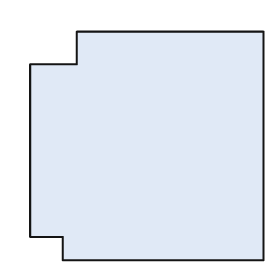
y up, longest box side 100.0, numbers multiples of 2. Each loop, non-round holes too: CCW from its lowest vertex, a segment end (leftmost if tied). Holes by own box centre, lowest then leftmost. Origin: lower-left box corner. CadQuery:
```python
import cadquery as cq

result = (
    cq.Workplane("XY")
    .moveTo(14.0, 0.0)
    .lineTo(100.0, 0.0)
    .lineTo(100.0, 98.0)
    .lineTo(20.0, 98.0)
    .lineTo(20.0, 84.0)
    .lineTo(0.0, 84.0)
    .lineTo(0.0, 10.0)
    .lineTo(14.0, 10.0)
    .close()
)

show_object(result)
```